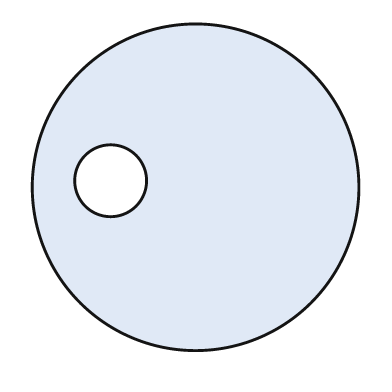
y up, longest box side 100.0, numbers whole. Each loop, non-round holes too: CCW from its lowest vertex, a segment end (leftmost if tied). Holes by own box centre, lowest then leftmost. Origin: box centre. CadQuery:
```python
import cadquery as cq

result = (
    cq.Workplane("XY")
    .moveTo(0.0, 0.0)
    .circle(50.0)
    .moveTo(-26.0, 2.0)
    .circle(11.0)
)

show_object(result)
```